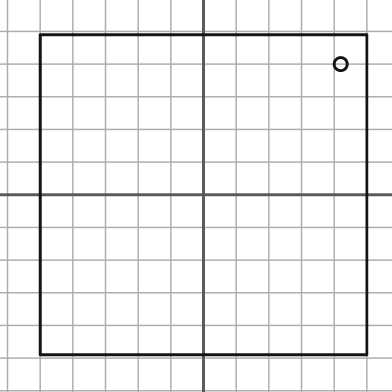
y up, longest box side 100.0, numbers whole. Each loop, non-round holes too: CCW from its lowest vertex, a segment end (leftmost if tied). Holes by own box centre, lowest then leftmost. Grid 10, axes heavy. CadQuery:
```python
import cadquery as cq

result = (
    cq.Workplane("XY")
    .moveTo(-50.0, -49.0)
    .lineTo(50.0, -49.0)
    .lineTo(50.0, 49.0)
    .lineTo(-50.0, 49.0)
    .close()
    .moveTo(42.0, 40.0)
    .circle(2.0)
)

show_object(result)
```